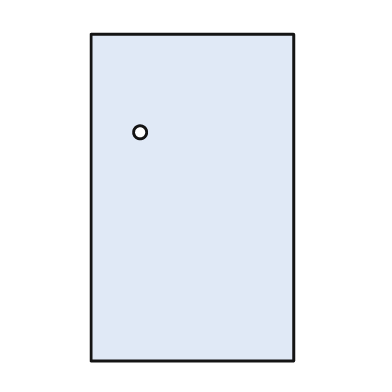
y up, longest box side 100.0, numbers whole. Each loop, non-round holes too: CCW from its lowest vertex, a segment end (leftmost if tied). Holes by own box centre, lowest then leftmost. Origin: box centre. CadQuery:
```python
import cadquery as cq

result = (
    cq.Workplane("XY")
    .moveTo(-31.0, -50.0)
    .lineTo(31.0, -50.0)
    .lineTo(31.0, 50.0)
    .lineTo(-31.0, 50.0)
    .close()
    .moveTo(-16.0, 20.0)
    .circle(2.0)
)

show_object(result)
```